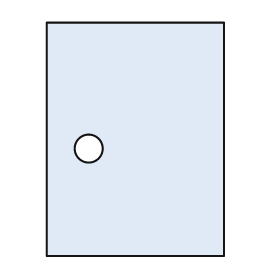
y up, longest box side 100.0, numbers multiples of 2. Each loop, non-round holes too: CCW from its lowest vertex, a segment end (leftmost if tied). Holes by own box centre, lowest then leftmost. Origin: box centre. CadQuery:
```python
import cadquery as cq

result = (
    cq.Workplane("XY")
    .moveTo(-38.0, -50.0)
    .lineTo(38.0, -50.0)
    .lineTo(38.0, 50.0)
    .lineTo(-38.0, 50.0)
    .close()
    .moveTo(-20.0, -4.0)
    .circle(6.0)
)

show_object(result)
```